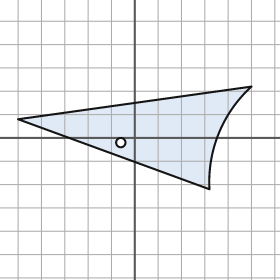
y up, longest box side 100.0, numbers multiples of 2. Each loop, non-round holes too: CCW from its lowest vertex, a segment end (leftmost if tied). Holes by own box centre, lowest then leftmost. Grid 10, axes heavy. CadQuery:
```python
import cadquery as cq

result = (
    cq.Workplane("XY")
    .moveTo(32.0, -22.0)
    .threePointArc((36.0, 2.0), (50.0, 22.0))
    .lineTo(-50.0, 8.0)
    .close()
    .moveTo(-6.0, -2.0)
    .circle(2.0)
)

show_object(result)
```